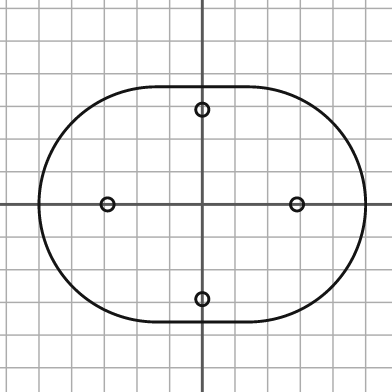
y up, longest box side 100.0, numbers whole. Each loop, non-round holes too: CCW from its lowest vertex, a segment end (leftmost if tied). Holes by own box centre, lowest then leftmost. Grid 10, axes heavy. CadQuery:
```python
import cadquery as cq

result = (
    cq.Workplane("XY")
    .moveTo(-14.0, -36.0)
    .lineTo(14.0, -36.0)
    .threePointArc((50.0, 0.0), (14.0, 36.0))
    .lineTo(-14.0, 36.0)
    .threePointArc((-50.0, 0.0), (-14.0, -36.0))
    .close()
    .moveTo(0.0, -29.0)
    .circle(2.0)
    .moveTo(-29.0, 0.0)
    .circle(2.0)
    .moveTo(29.0, 0.0)
    .circle(2.0)
    .moveTo(0.0, 29.0)
    .circle(2.0)
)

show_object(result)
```